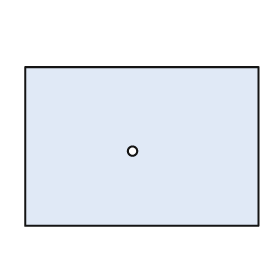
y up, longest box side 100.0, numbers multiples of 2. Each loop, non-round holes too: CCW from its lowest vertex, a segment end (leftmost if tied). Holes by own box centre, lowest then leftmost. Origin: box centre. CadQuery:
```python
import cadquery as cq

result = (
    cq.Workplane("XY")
    .moveTo(-50.0, -34.0)
    .lineTo(50.0, -34.0)
    .lineTo(50.0, 34.0)
    .lineTo(-50.0, 34.0)
    .close()
    .moveTo(-4.0, -2.0)
    .circle(2.0)
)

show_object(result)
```